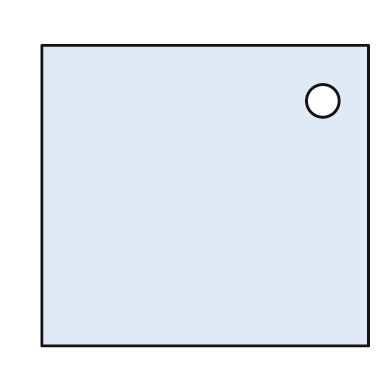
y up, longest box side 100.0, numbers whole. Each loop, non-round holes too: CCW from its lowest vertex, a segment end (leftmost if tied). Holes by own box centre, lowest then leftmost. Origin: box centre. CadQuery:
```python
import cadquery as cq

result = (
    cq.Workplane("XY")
    .moveTo(-50.0, -46.0)
    .lineTo(50.0, -46.0)
    .lineTo(50.0, 46.0)
    .lineTo(-50.0, 46.0)
    .close()
    .moveTo(36.0, 29.0)
    .circle(5.0)
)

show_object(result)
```